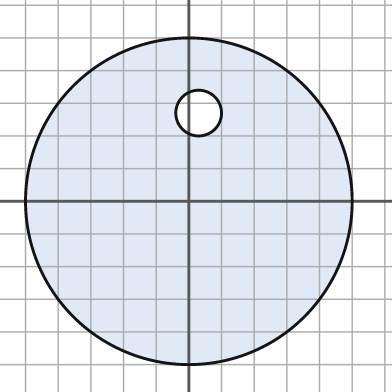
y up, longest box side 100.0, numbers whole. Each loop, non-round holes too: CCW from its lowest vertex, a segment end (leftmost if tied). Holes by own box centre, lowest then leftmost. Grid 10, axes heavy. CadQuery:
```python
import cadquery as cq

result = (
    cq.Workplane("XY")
    .moveTo(0.0, 0.0)
    .circle(50.0)
    .moveTo(3.0, 27.0)
    .circle(7.0)
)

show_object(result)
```